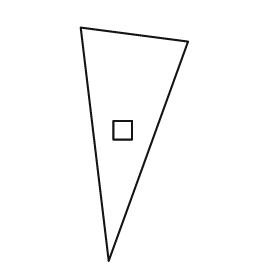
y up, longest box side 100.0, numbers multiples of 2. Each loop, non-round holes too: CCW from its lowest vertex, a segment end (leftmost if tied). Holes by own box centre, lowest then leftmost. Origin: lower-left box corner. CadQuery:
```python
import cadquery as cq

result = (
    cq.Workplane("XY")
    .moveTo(12.0, 0.0)
    .lineTo(46.0, 94.0)
    .lineTo(0.0, 100.0)
    .close()
    .moveTo(14.0, 52.0)
    .lineTo(22.0, 52.0)
    .lineTo(22.0, 60.0)
    .lineTo(14.0, 60.0)
    .close()
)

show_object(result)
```